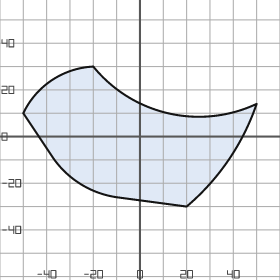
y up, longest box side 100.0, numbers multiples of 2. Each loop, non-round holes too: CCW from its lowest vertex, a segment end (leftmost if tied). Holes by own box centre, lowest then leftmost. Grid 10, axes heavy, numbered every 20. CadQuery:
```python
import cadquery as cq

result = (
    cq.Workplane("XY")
    .moveTo(20.0, -30.0)
    .threePointArc((38.0, -10.0), (50.0, 14.0))
    .threePointArc((12.0, 10.0), (-20.0, 30.0))
    .threePointArc((-38.0, 24.0), (-50.0, 10.0))
    .lineTo(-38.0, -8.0)
    .threePointArc((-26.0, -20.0), (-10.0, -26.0))
    .close()
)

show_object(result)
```